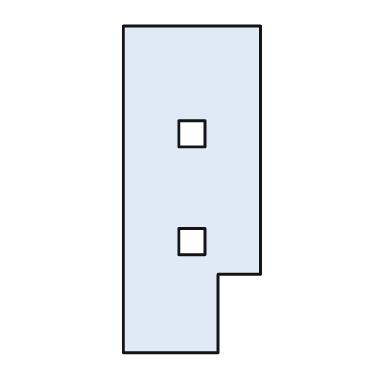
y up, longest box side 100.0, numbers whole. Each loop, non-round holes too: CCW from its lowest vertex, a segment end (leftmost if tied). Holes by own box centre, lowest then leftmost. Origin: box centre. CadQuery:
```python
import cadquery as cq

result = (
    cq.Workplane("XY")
    .moveTo(-21.0, -50.0)
    .lineTo(8.0, -50.0)
    .lineTo(8.0, -26.0)
    .lineTo(21.0, -26.0)
    .lineTo(21.0, 50.0)
    .lineTo(-21.0, 50.0)
    .close()
    .moveTo(-4.0, -20.0)
    .lineTo(4.0, -20.0)
    .lineTo(4.0, -12.0)
    .lineTo(-4.0, -12.0)
    .close()
    .moveTo(-4.0, 13.0)
    .lineTo(4.0, 13.0)
    .lineTo(4.0, 21.0)
    .lineTo(-4.0, 21.0)
    .close()
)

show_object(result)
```